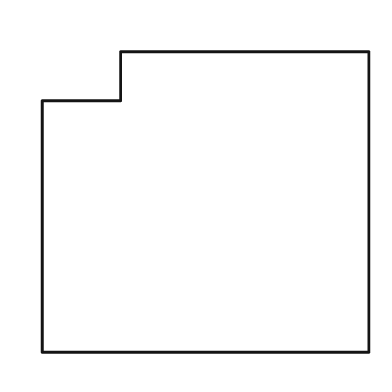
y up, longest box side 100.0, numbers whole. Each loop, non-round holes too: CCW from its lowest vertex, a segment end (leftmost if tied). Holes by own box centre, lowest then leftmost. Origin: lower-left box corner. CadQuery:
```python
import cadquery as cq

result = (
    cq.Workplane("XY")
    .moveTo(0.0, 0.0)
    .lineTo(100.0, 0.0)
    .lineTo(100.0, 92.0)
    .lineTo(24.0, 92.0)
    .lineTo(24.0, 77.0)
    .lineTo(0.0, 77.0)
    .close()
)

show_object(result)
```